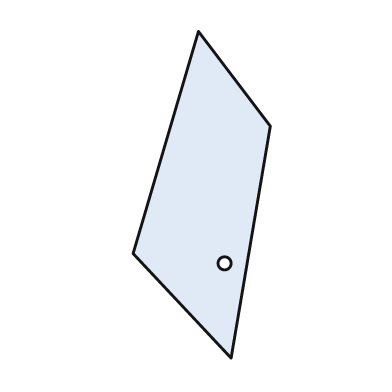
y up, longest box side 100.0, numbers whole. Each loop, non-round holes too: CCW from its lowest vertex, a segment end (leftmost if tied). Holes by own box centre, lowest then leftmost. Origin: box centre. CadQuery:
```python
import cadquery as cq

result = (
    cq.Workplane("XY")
    .moveTo(9.0, -50.0)
    .lineTo(21.0, 21.0)
    .lineTo(-1.0, 50.0)
    .lineTo(-21.0, -18.0)
    .close()
    .moveTo(7.0, -21.0)
    .circle(2.0)
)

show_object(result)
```